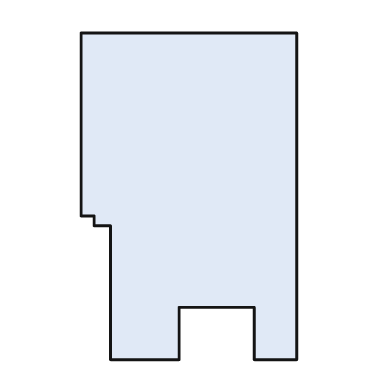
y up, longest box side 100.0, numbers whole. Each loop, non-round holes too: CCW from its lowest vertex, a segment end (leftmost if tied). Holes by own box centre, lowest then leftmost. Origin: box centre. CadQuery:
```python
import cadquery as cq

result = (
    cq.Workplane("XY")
    .moveTo(-24.0, -50.0)
    .lineTo(-3.0, -50.0)
    .lineTo(-3.0, -34.0)
    .lineTo(20.0, -34.0)
    .lineTo(20.0, -50.0)
    .lineTo(33.0, -50.0)
    .lineTo(33.0, 50.0)
    .lineTo(-33.0, 50.0)
    .lineTo(-33.0, -6.0)
    .lineTo(-29.0, -6.0)
    .lineTo(-29.0, -9.0)
    .lineTo(-24.0, -9.0)
    .close()
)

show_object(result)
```